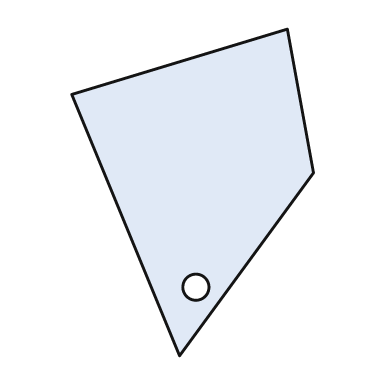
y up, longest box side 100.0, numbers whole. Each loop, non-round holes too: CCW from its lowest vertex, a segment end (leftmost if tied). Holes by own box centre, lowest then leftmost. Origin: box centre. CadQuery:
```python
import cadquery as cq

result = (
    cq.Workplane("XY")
    .moveTo(-4.0, -50.0)
    .lineTo(37.0, 6.0)
    .lineTo(29.0, 50.0)
    .lineTo(-37.0, 30.0)
    .close()
    .moveTo(1.0, -29.0)
    .circle(4.0)
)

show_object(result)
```